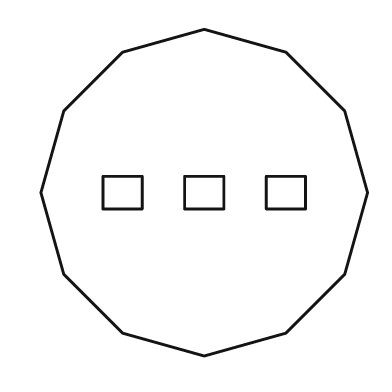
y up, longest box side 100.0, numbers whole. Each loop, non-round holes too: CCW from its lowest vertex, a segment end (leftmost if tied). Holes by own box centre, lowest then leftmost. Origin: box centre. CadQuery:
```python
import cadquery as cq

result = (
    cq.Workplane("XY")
    .moveTo(0.0, -50.0)
    .lineTo(25.0, -43.0)
    .lineTo(43.0, -25.0)
    .lineTo(50.0, 0.0)
    .lineTo(43.0, 25.0)
    .lineTo(25.0, 43.0)
    .lineTo(0.0, 50.0)
    .lineTo(-25.0, 43.0)
    .lineTo(-43.0, 25.0)
    .lineTo(-50.0, 0.0)
    .lineTo(-43.0, -25.0)
    .lineTo(-25.0, -43.0)
    .close()
    .moveTo(-31.0, -5.0)
    .lineTo(-19.0, -5.0)
    .lineTo(-19.0, 5.0)
    .lineTo(-31.0, 5.0)
    .close()
    .moveTo(-6.0, -5.0)
    .lineTo(6.0, -5.0)
    .lineTo(6.0, 5.0)
    .lineTo(-6.0, 5.0)
    .close()
    .moveTo(19.0, -5.0)
    .lineTo(31.0, -5.0)
    .lineTo(31.0, 5.0)
    .lineTo(19.0, 5.0)
    .close()
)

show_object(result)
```